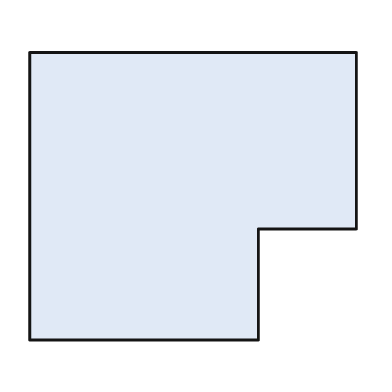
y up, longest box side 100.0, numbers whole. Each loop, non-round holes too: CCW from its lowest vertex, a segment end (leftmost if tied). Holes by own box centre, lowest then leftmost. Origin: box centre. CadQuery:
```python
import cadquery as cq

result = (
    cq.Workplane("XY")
    .moveTo(-50.0, -44.0)
    .lineTo(20.0, -44.0)
    .lineTo(20.0, -10.0)
    .lineTo(50.0, -10.0)
    .lineTo(50.0, 44.0)
    .lineTo(-50.0, 44.0)
    .close()
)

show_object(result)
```